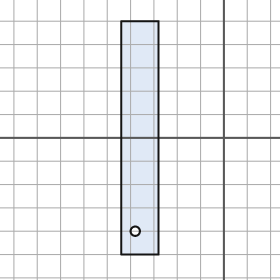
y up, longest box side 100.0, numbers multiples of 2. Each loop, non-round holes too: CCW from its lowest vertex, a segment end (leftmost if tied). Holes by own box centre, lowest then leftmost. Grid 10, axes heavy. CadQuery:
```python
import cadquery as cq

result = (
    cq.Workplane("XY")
    .moveTo(-44.0, -50.0)
    .lineTo(-28.0, -50.0)
    .lineTo(-28.0, 50.0)
    .lineTo(-44.0, 50.0)
    .close()
    .moveTo(-38.0, -40.0)
    .circle(2.0)
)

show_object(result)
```